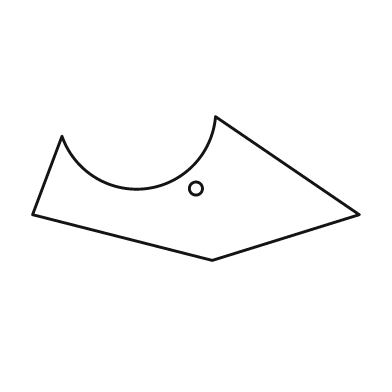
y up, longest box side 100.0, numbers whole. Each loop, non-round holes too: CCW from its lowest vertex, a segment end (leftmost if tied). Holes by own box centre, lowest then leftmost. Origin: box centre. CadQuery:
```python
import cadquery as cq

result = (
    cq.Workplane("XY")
    .moveTo(5.0, -22.0)
    .lineTo(50.0, -8.0)
    .lineTo(6.0, 22.0)
    .threePointArc((-15.0, 0.0), (-41.0, 16.0))
    .lineTo(-50.0, -8.0)
    .close()
    .moveTo(0.0, 0.0)
    .circle(2.0)
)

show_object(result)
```